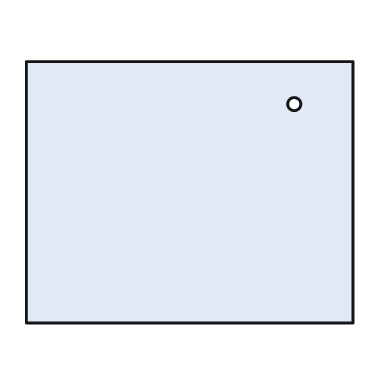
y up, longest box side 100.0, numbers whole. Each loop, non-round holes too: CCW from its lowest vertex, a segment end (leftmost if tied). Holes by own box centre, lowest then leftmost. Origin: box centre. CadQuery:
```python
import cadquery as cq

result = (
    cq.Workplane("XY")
    .moveTo(-50.0, -40.0)
    .lineTo(50.0, -40.0)
    .lineTo(50.0, 40.0)
    .lineTo(-50.0, 40.0)
    .close()
    .moveTo(32.0, 27.0)
    .circle(2.0)
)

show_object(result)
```